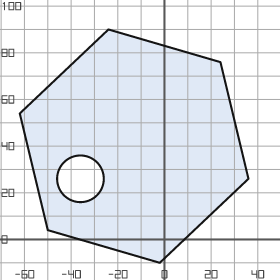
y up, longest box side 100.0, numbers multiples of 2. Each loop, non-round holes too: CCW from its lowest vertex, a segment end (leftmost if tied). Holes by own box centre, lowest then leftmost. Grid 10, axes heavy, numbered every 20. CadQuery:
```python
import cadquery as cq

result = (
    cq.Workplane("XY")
    .moveTo(-2.0, -10.0)
    .lineTo(36.0, 26.0)
    .lineTo(24.0, 76.0)
    .lineTo(-24.0, 90.0)
    .lineTo(-62.0, 54.0)
    .lineTo(-50.0, 4.0)
    .close()
    .moveTo(-36.0, 26.0)
    .circle(10.0)
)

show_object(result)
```